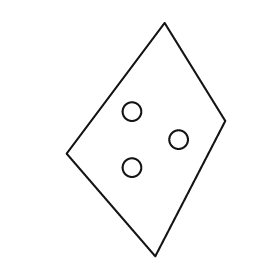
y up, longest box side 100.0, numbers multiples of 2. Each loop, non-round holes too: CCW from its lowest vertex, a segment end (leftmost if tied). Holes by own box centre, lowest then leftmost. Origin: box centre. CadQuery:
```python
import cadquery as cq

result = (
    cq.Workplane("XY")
    .moveTo(4.0, -50.0)
    .lineTo(34.0, 8.0)
    .lineTo(8.0, 50.0)
    .lineTo(-34.0, -6.0)
    .close()
    .moveTo(-6.0, -12.0)
    .circle(4.0)
    .moveTo(14.0, 0.0)
    .circle(4.0)
    .moveTo(-6.0, 12.0)
    .circle(4.0)
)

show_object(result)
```